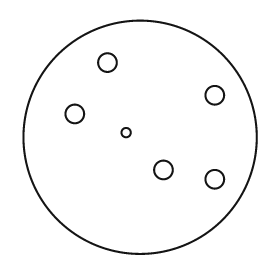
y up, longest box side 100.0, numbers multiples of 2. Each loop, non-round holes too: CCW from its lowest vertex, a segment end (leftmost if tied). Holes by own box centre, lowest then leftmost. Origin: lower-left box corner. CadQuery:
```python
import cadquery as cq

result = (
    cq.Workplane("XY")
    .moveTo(50.0, 50.0)
    .circle(50.0)
    .moveTo(82.0, 32.0)
    .circle(4.0)
    .moveTo(60.0, 36.0)
    .circle(4.0)
    .moveTo(44.0, 52.0)
    .circle(2.0)
    .moveTo(22.0, 60.0)
    .circle(4.0)
    .moveTo(82.0, 68.0)
    .circle(4.0)
    .moveTo(36.0, 82.0)
    .circle(4.0)
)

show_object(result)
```